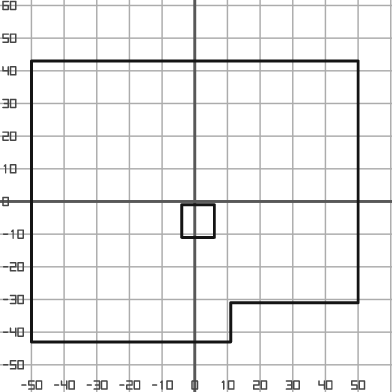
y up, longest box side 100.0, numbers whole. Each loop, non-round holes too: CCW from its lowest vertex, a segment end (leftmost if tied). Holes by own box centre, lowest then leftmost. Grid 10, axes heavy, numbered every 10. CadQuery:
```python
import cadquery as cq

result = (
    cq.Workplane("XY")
    .moveTo(-50.0, -43.0)
    .lineTo(11.0, -43.0)
    .lineTo(11.0, -31.0)
    .lineTo(50.0, -31.0)
    .lineTo(50.0, 43.0)
    .lineTo(-50.0, 43.0)
    .close()
    .moveTo(-4.0, -11.0)
    .lineTo(6.0, -11.0)
    .lineTo(6.0, -1.0)
    .lineTo(-4.0, -1.0)
    .close()
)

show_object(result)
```